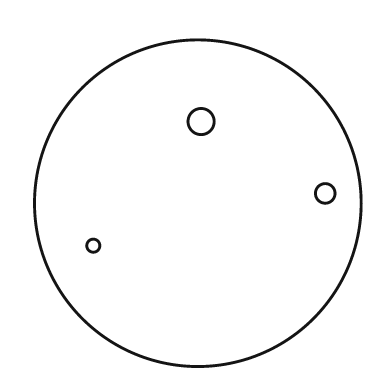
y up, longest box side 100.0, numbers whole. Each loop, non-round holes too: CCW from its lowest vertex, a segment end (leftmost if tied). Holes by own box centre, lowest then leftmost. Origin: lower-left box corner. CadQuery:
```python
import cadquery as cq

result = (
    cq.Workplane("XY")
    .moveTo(50.0, 50.0)
    .circle(50.0)
    .moveTo(18.0, 37.0)
    .circle(2.0)
    .moveTo(89.0, 53.0)
    .circle(3.0)
    .moveTo(51.0, 75.0)
    .circle(4.0)
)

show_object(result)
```